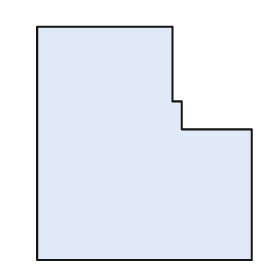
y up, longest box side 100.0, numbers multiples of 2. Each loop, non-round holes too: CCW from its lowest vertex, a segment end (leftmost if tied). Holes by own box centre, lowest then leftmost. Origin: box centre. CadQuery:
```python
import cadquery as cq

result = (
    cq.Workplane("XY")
    .moveTo(-46.0, -50.0)
    .lineTo(46.0, -50.0)
    .lineTo(46.0, 6.0)
    .lineTo(16.0, 6.0)
    .lineTo(16.0, 18.0)
    .lineTo(12.0, 18.0)
    .lineTo(12.0, 50.0)
    .lineTo(-46.0, 50.0)
    .close()
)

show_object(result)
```